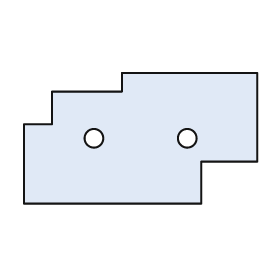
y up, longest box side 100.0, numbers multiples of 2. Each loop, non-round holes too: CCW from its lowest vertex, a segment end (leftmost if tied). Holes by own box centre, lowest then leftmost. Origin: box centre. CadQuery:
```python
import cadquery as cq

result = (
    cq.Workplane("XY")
    .moveTo(-50.0, -28.0)
    .lineTo(26.0, -28.0)
    .lineTo(26.0, -10.0)
    .lineTo(50.0, -10.0)
    .lineTo(50.0, 28.0)
    .lineTo(-8.0, 28.0)
    .lineTo(-8.0, 20.0)
    .lineTo(-38.0, 20.0)
    .lineTo(-38.0, 6.0)
    .lineTo(-50.0, 6.0)
    .close()
    .moveTo(-20.0, 0.0)
    .circle(4.0)
    .moveTo(20.0, 0.0)
    .circle(4.0)
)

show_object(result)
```